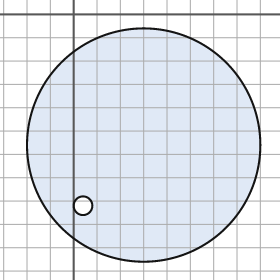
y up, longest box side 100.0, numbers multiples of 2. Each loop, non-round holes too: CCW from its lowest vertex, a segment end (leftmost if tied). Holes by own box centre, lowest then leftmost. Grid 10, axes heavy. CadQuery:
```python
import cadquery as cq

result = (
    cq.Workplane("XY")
    .moveTo(30.0, -56.0)
    .circle(50.0)
    .moveTo(4.0, -82.0)
    .circle(4.0)
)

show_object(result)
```